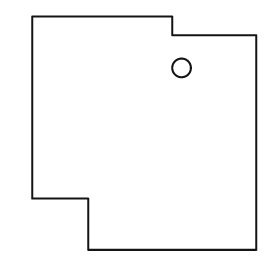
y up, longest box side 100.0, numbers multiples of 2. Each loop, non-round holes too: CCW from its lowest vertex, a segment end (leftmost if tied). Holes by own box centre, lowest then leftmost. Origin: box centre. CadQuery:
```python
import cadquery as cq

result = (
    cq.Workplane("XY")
    .moveTo(-24.0, -50.0)
    .lineTo(48.0, -50.0)
    .lineTo(48.0, 42.0)
    .lineTo(12.0, 42.0)
    .lineTo(12.0, 50.0)
    .lineTo(-48.0, 50.0)
    .lineTo(-48.0, -28.0)
    .lineTo(-24.0, -28.0)
    .close()
    .moveTo(16.0, 28.0)
    .circle(4.0)
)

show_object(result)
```